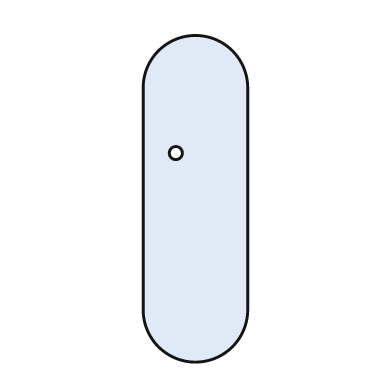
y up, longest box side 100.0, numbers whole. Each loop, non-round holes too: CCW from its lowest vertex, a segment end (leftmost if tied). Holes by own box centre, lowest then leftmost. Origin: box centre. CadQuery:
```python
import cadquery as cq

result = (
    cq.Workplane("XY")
    .moveTo(-16.0, -34.0)
    .threePointArc((0.0, -50.0), (16.0, -34.0))
    .lineTo(16.0, 34.0)
    .threePointArc((0.0, 50.0), (-16.0, 34.0))
    .close()
    .moveTo(-6.0, 14.0)
    .circle(2.0)
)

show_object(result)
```